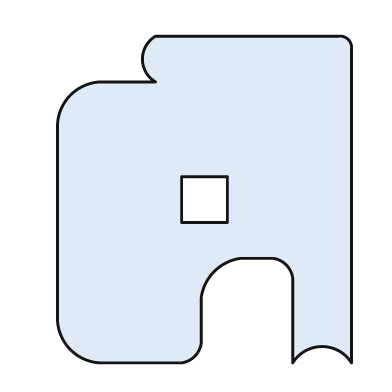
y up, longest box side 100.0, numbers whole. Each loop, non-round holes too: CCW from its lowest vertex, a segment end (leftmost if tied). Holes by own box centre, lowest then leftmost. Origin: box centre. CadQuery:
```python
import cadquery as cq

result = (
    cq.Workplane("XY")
    .moveTo(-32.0, -50.0)
    .lineTo(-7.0, -50.0)
    .threePointArc((-3.0, -48.0), (-1.0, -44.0))
    .lineTo(-1.0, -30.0)
    .threePointArc((3.0, -22.0), (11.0, -18.0))
    .lineTo(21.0, -18.0)
    .threePointArc((25.0, -20.0), (27.0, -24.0))
    .lineTo(27.0, -50.0)
    .threePointArc((36.0, -45.0), (45.0, -50.0))
    .lineTo(45.0, 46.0)
    .threePointArc((44.0, 49.0), (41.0, 50.0))
    .lineTo(-15.0, 50.0)
    .threePointArc((-19.0, 43.0), (-15.0, 36.0))
    .lineTo(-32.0, 36.0)
    .threePointArc((-41.0, 32.0), (-45.0, 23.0))
    .lineTo(-45.0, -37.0)
    .threePointArc((-41.0, -46.0), (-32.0, -50.0))
    .close()
    .moveTo(-7.0, -7.0)
    .lineTo(7.0, -7.0)
    .lineTo(7.0, 7.0)
    .lineTo(-7.0, 7.0)
    .close()
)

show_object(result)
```